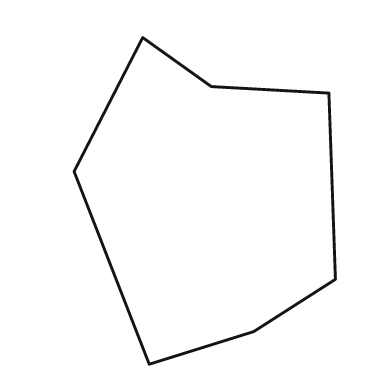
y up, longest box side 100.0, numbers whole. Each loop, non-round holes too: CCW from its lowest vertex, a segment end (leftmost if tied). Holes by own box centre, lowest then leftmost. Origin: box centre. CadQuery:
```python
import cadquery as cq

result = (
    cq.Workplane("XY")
    .moveTo(-17.0, -50.0)
    .lineTo(15.0, -40.0)
    .lineTo(40.0, -24.0)
    .lineTo(38.0, 33.0)
    .lineTo(2.0, 35.0)
    .lineTo(-19.0, 50.0)
    .lineTo(-40.0, 9.0)
    .close()
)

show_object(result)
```